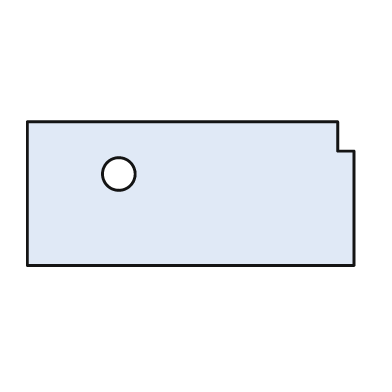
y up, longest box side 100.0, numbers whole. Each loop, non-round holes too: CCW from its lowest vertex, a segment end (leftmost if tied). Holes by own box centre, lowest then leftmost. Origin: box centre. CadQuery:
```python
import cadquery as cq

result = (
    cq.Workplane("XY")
    .moveTo(-50.0, -22.0)
    .lineTo(50.0, -22.0)
    .lineTo(50.0, 13.0)
    .lineTo(45.0, 13.0)
    .lineTo(45.0, 22.0)
    .lineTo(-50.0, 22.0)
    .close()
    .moveTo(-22.0, 6.0)
    .circle(5.0)
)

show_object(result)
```